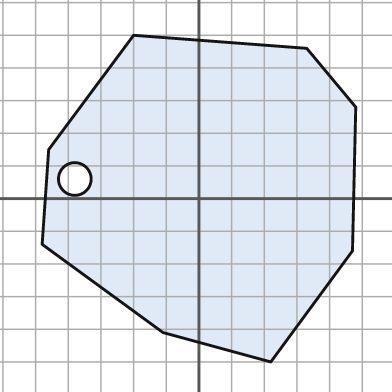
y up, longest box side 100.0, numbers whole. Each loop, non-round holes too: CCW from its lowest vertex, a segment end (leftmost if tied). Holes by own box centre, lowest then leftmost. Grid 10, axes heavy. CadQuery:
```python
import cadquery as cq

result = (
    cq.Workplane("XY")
    .moveTo(22.0, -50.0)
    .lineTo(47.0, -16.0)
    .lineTo(48.0, 28.0)
    .lineTo(33.0, 46.0)
    .lineTo(-20.0, 50.0)
    .lineTo(-46.0, 15.0)
    .lineTo(-48.0, -14.0)
    .lineTo(-11.0, -41.0)
    .close()
    .moveTo(-38.0, 6.0)
    .circle(5.0)
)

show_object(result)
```